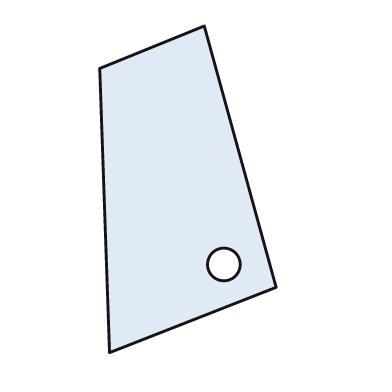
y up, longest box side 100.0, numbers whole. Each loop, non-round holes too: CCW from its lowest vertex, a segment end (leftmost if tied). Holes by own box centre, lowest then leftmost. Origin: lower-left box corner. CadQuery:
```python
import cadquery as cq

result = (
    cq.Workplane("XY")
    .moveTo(3.0, 0.0)
    .lineTo(54.0, 20.0)
    .lineTo(32.0, 100.0)
    .lineTo(0.0, 87.0)
    .close()
    .moveTo(38.0, 27.0)
    .circle(5.0)
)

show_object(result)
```